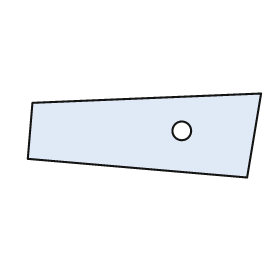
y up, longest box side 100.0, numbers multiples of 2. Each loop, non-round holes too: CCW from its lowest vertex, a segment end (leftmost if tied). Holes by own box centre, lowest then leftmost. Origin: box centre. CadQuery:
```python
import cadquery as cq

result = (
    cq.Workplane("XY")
    .moveTo(44.0, -18.0)
    .lineTo(50.0, 18.0)
    .lineTo(-48.0, 14.0)
    .lineTo(-50.0, -10.0)
    .close()
    .moveTo(16.0, 2.0)
    .circle(4.0)
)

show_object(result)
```